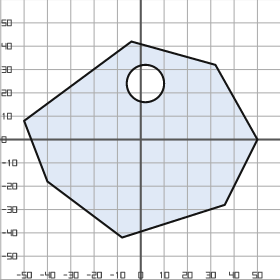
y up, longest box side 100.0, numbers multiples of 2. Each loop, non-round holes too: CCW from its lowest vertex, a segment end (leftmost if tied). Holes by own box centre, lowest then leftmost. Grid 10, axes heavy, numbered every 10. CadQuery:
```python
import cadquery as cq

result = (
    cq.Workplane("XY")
    .moveTo(-8.0, -42.0)
    .lineTo(36.0, -28.0)
    .lineTo(50.0, 0.0)
    .lineTo(32.0, 32.0)
    .lineTo(-4.0, 42.0)
    .lineTo(-50.0, 8.0)
    .lineTo(-40.0, -18.0)
    .close()
    .moveTo(2.0, 24.0)
    .circle(8.0)
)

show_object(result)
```